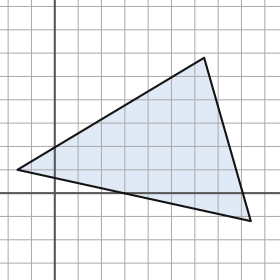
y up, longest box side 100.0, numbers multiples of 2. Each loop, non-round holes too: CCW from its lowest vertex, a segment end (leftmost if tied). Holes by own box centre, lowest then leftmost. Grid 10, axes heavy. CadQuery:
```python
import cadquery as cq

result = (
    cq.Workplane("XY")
    .moveTo(84.0, -12.0)
    .lineTo(64.0, 58.0)
    .lineTo(-16.0, 10.0)
    .close()
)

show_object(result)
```